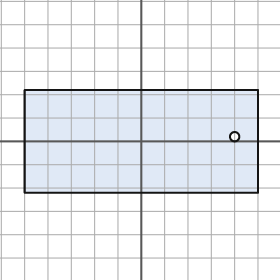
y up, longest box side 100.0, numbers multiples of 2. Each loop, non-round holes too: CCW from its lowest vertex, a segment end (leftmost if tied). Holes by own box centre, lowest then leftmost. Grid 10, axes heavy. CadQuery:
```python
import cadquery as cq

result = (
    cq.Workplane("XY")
    .moveTo(-50.0, -22.0)
    .lineTo(50.0, -22.0)
    .lineTo(50.0, 22.0)
    .lineTo(-50.0, 22.0)
    .close()
    .moveTo(40.0, 2.0)
    .circle(2.0)
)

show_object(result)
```